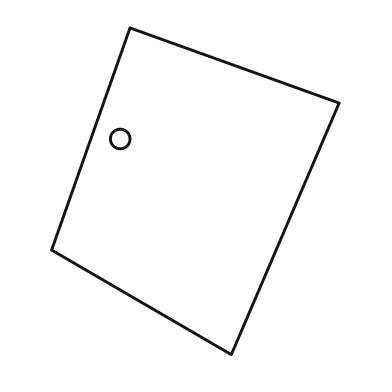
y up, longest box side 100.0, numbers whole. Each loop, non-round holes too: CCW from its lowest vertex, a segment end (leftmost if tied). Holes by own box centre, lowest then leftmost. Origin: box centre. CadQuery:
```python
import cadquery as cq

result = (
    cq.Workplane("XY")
    .moveTo(11.0, -50.0)
    .lineTo(44.0, 27.0)
    .lineTo(-20.0, 50.0)
    .lineTo(-44.0, -18.0)
    .close()
    .moveTo(-23.0, 16.0)
    .circle(3.0)
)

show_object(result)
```